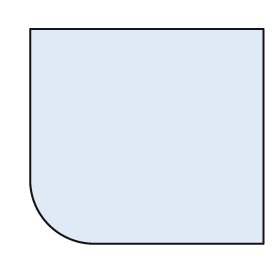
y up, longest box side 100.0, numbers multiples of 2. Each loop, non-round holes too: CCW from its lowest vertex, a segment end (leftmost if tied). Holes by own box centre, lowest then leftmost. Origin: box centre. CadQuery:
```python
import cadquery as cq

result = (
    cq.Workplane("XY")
    .moveTo(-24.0, -46.0)
    .lineTo(50.0, -46.0)
    .lineTo(50.0, 46.0)
    .lineTo(-50.0, 46.0)
    .lineTo(-50.0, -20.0)
    .threePointArc((-42.0, -38.0), (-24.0, -46.0))
    .close()
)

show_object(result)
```